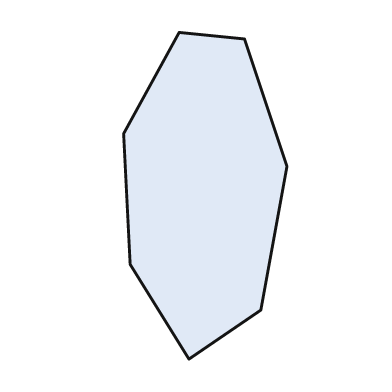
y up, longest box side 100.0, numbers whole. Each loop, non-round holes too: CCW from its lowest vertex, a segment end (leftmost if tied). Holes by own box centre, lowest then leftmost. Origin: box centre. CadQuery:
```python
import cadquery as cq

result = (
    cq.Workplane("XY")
    .moveTo(-5.0, -50.0)
    .lineTo(17.0, -35.0)
    .lineTo(25.0, 9.0)
    .lineTo(12.0, 48.0)
    .lineTo(-8.0, 50.0)
    .lineTo(-25.0, 19.0)
    .lineTo(-23.0, -21.0)
    .close()
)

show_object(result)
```